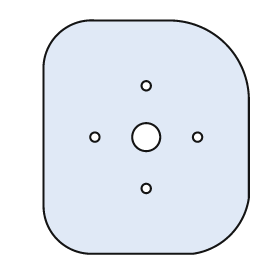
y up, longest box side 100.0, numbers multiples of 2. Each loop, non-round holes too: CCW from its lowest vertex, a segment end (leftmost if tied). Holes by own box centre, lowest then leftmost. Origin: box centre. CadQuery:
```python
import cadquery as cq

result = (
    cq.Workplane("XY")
    .moveTo(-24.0, -50.0)
    .lineTo(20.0, -50.0)
    .threePointArc((36.0, -42.0), (44.0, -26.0))
    .lineTo(44.0, 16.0)
    .threePointArc((34.0, 40.0), (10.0, 50.0))
    .lineTo(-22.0, 50.0)
    .threePointArc((-38.0, 44.0), (-44.0, 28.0))
    .lineTo(-44.0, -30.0)
    .threePointArc((-38.0, -44.0), (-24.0, -50.0))
    .close()
    .moveTo(0.0, -22.0)
    .circle(2.0)
    .moveTo(-22.0, 0.0)
    .circle(2.0)
    .moveTo(0.0, 0.0)
    .circle(6.0)
    .moveTo(22.0, 0.0)
    .circle(2.0)
    .moveTo(0.0, 22.0)
    .circle(2.0)
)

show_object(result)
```